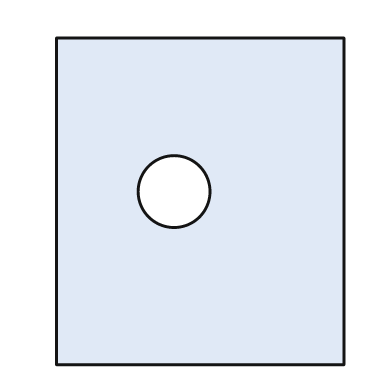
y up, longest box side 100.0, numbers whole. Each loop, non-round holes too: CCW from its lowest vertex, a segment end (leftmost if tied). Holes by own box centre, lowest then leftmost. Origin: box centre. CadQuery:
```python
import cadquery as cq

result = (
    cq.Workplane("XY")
    .moveTo(-44.0, -50.0)
    .lineTo(44.0, -50.0)
    .lineTo(44.0, 50.0)
    .lineTo(-44.0, 50.0)
    .close()
    .moveTo(-8.0, 3.0)
    .circle(11.0)
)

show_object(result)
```